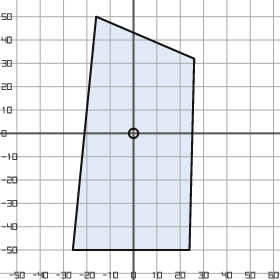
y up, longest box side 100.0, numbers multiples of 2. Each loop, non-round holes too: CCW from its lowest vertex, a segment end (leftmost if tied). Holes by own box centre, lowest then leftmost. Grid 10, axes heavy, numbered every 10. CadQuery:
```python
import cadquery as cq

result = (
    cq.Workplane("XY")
    .moveTo(-26.0, -50.0)
    .lineTo(24.0, -50.0)
    .lineTo(26.0, 32.0)
    .lineTo(-16.0, 50.0)
    .close()
    .moveTo(0.0, 0.0)
    .circle(2.0)
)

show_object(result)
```